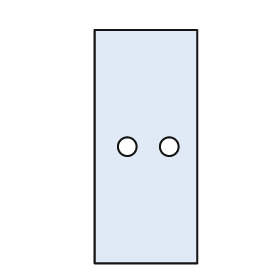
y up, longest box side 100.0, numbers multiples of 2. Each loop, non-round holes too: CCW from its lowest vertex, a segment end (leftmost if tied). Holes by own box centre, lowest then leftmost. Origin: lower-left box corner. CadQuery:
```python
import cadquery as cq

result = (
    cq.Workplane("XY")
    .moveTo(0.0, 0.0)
    .lineTo(44.0, 0.0)
    .lineTo(44.0, 100.0)
    .lineTo(0.0, 100.0)
    .close()
    .moveTo(14.0, 50.0)
    .circle(4.0)
    .moveTo(32.0, 50.0)
    .circle(4.0)
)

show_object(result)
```